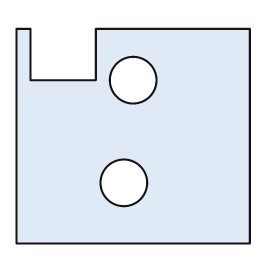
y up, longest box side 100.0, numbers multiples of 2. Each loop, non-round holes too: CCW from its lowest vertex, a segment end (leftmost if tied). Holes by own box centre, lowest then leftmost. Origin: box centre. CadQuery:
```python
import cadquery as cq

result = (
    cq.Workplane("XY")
    .moveTo(-50.0, -46.0)
    .lineTo(50.0, -46.0)
    .lineTo(50.0, 46.0)
    .lineTo(-16.0, 46.0)
    .lineTo(-16.0, 24.0)
    .lineTo(-44.0, 24.0)
    .lineTo(-44.0, 46.0)
    .lineTo(-50.0, 46.0)
    .close()
    .moveTo(-4.0, -20.0)
    .circle(10.0)
    .moveTo(0.0, 24.0)
    .circle(10.0)
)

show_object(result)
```